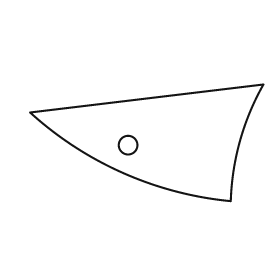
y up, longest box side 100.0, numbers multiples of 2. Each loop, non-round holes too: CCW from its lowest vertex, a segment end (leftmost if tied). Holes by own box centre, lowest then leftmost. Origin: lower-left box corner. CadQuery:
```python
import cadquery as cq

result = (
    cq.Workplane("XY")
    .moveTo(86.0, 0.0)
    .threePointArc((90.0, 26.0), (100.0, 50.0))
    .lineTo(0.0, 38.0)
    .threePointArc((40.0, 12.0), (86.0, 0.0))
    .close()
    .moveTo(42.0, 24.0)
    .circle(4.0)
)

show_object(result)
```